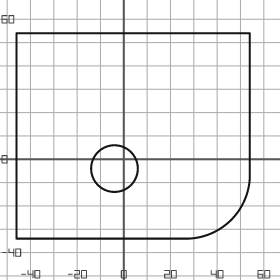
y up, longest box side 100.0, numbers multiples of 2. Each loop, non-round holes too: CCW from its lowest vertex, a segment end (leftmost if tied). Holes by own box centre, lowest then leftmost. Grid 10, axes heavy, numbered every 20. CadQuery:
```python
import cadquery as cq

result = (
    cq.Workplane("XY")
    .moveTo(-46.0, -34.0)
    .lineTo(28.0, -34.0)
    .threePointArc((46.0, -26.0), (54.0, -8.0))
    .lineTo(54.0, 54.0)
    .lineTo(-46.0, 54.0)
    .close()
    .moveTo(-4.0, -4.0)
    .circle(10.0)
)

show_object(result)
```